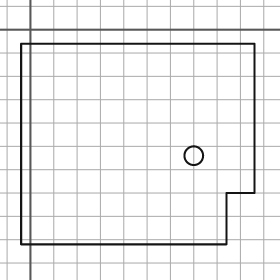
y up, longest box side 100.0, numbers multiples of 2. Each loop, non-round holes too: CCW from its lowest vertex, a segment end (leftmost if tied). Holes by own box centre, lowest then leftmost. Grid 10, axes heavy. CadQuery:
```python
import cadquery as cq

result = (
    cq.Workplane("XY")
    .moveTo(-4.0, -92.0)
    .lineTo(84.0, -92.0)
    .lineTo(84.0, -70.0)
    .lineTo(96.0, -70.0)
    .lineTo(96.0, -6.0)
    .lineTo(-4.0, -6.0)
    .close()
    .moveTo(70.0, -54.0)
    .circle(4.0)
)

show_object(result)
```